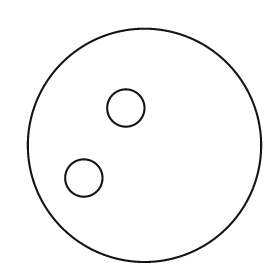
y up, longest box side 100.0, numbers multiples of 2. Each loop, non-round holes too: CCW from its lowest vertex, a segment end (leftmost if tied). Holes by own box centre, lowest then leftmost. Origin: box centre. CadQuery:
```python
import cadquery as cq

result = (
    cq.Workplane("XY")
    .moveTo(0.0, 0.0)
    .circle(50.0)
    .moveTo(-26.0, -14.0)
    .circle(8.0)
    .moveTo(-8.0, 16.0)
    .circle(8.0)
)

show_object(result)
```